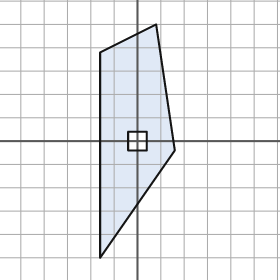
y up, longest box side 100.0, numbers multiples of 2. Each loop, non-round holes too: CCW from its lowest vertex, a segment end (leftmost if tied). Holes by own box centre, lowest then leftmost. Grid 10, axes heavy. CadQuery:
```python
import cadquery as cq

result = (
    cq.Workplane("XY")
    .moveTo(-16.0, -50.0)
    .lineTo(16.0, -4.0)
    .lineTo(8.0, 50.0)
    .lineTo(-16.0, 38.0)
    .close()
    .moveTo(-4.0, -4.0)
    .lineTo(4.0, -4.0)
    .lineTo(4.0, 4.0)
    .lineTo(-4.0, 4.0)
    .close()
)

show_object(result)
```